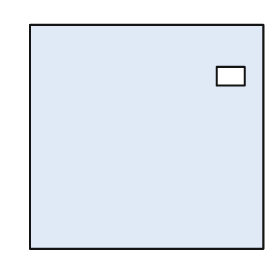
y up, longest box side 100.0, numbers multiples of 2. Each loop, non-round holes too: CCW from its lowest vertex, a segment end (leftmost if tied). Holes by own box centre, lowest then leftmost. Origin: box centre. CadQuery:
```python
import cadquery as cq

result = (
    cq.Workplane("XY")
    .moveTo(-50.0, -48.0)
    .lineTo(50.0, -48.0)
    .lineTo(50.0, 48.0)
    .lineTo(-50.0, 48.0)
    .close()
    .moveTo(30.0, 22.0)
    .lineTo(42.0, 22.0)
    .lineTo(42.0, 30.0)
    .lineTo(30.0, 30.0)
    .close()
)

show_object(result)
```